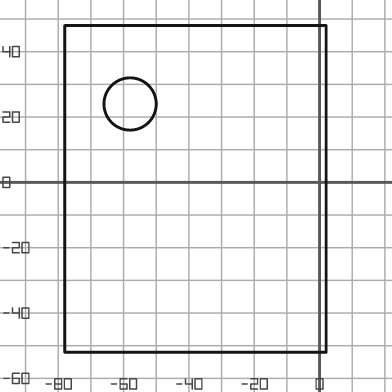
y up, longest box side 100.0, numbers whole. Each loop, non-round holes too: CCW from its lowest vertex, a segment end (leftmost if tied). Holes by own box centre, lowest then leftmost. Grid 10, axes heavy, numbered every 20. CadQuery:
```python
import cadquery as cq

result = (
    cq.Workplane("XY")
    .moveTo(-78.0, -52.0)
    .lineTo(2.0, -52.0)
    .lineTo(2.0, 48.0)
    .lineTo(-78.0, 48.0)
    .close()
    .moveTo(-58.0, 24.0)
    .circle(8.0)
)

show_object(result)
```